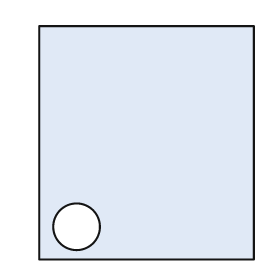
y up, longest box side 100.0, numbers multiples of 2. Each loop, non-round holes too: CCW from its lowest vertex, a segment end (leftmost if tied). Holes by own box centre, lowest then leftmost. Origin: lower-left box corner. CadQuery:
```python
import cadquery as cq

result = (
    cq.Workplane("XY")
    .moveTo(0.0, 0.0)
    .lineTo(92.0, 0.0)
    .lineTo(92.0, 100.0)
    .lineTo(0.0, 100.0)
    .close()
    .moveTo(16.0, 14.0)
    .circle(10.0)
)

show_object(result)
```